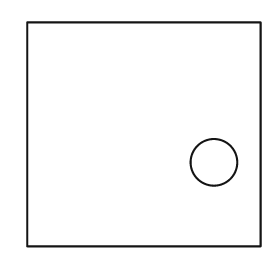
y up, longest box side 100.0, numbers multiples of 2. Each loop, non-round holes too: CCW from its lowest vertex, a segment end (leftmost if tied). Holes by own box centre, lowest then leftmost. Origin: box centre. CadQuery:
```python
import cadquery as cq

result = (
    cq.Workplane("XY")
    .moveTo(-50.0, -48.0)
    .lineTo(50.0, -48.0)
    .lineTo(50.0, 48.0)
    .lineTo(-50.0, 48.0)
    .close()
    .moveTo(30.0, -12.0)
    .circle(10.0)
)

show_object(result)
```